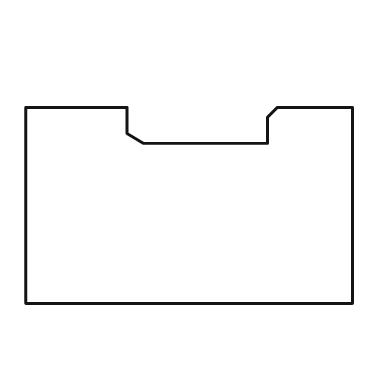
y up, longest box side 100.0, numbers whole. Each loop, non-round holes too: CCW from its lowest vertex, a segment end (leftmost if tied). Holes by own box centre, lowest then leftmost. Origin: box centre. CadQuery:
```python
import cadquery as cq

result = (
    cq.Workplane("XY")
    .moveTo(-50.0, -30.0)
    .lineTo(50.0, -30.0)
    .lineTo(50.0, 30.0)
    .lineTo(27.0, 30.0)
    .lineTo(24.0, 27.0)
    .lineTo(24.0, 19.0)
    .lineTo(-14.0, 19.0)
    .lineTo(-19.0, 22.0)
    .lineTo(-19.0, 30.0)
    .lineTo(-50.0, 30.0)
    .close()
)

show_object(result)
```